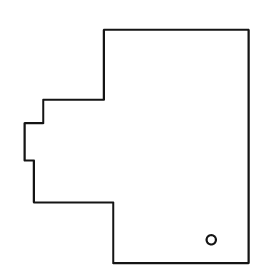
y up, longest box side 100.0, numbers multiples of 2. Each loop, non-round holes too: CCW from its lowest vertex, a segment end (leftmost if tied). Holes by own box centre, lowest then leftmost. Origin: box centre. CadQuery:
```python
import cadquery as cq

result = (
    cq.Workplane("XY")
    .moveTo(-10.0, -50.0)
    .lineTo(48.0, -50.0)
    .lineTo(48.0, 50.0)
    .lineTo(-14.0, 50.0)
    .lineTo(-14.0, 20.0)
    .lineTo(-40.0, 20.0)
    .lineTo(-40.0, 10.0)
    .lineTo(-48.0, 10.0)
    .lineTo(-48.0, -6.0)
    .lineTo(-44.0, -6.0)
    .lineTo(-44.0, -24.0)
    .lineTo(-10.0, -24.0)
    .close()
    .moveTo(32.0, -40.0)
    .circle(2.0)
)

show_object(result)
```